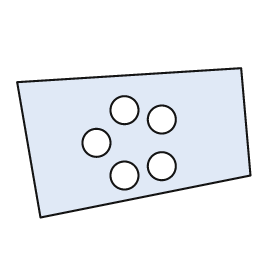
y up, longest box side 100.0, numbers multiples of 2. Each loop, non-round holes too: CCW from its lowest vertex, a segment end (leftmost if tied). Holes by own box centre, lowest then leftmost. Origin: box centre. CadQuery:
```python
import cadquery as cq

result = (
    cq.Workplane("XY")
    .moveTo(-40.0, -32.0)
    .lineTo(50.0, -14.0)
    .lineTo(46.0, 32.0)
    .lineTo(-50.0, 26.0)
    .close()
    .moveTo(-4.0, -14.0)
    .circle(6.0)
    .moveTo(12.0, -10.0)
    .circle(6.0)
    .moveTo(-16.0, 0.0)
    .circle(6.0)
    .moveTo(12.0, 10.0)
    .circle(6.0)
    .moveTo(-4.0, 14.0)
    .circle(6.0)
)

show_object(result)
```